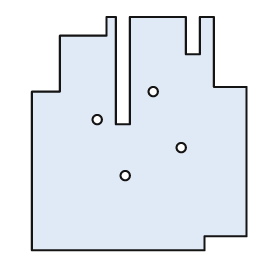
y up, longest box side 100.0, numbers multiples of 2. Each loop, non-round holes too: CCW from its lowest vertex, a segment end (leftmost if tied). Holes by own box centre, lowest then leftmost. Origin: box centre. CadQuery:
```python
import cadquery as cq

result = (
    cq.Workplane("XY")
    .moveTo(-46.0, -50.0)
    .lineTo(28.0, -50.0)
    .lineTo(28.0, -44.0)
    .lineTo(46.0, -44.0)
    .lineTo(46.0, 20.0)
    .lineTo(32.0, 20.0)
    .lineTo(32.0, 50.0)
    .lineTo(26.0, 50.0)
    .lineTo(26.0, 34.0)
    .lineTo(20.0, 34.0)
    .lineTo(20.0, 50.0)
    .lineTo(-4.0, 50.0)
    .lineTo(-4.0, 4.0)
    .lineTo(-10.0, 4.0)
    .lineTo(-10.0, 50.0)
    .lineTo(-14.0, 50.0)
    .lineTo(-14.0, 42.0)
    .lineTo(-34.0, 42.0)
    .lineTo(-34.0, 18.0)
    .lineTo(-46.0, 18.0)
    .close()
    .moveTo(-6.0, -18.0)
    .circle(2.0)
    .moveTo(18.0, -6.0)
    .circle(2.0)
    .moveTo(-18.0, 6.0)
    .circle(2.0)
    .moveTo(6.0, 18.0)
    .circle(2.0)
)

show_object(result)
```